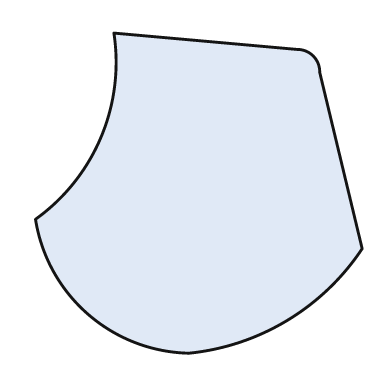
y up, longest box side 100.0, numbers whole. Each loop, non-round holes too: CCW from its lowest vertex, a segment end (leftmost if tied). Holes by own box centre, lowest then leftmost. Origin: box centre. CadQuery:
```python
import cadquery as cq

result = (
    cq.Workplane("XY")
    .moveTo(-3.0, -49.0)
    .threePointArc((27.0, -39.0), (50.0, -17.0))
    .lineTo(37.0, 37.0)
    .threePointArc((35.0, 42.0), (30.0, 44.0))
    .lineTo(-26.0, 49.0)
    .threePointArc((-30.0, 17.0), (-50.0, -8.0))
    .threePointArc((-34.0, -37.0), (-3.0, -49.0))
    .close()
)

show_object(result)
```